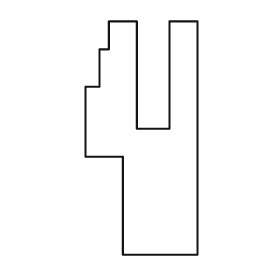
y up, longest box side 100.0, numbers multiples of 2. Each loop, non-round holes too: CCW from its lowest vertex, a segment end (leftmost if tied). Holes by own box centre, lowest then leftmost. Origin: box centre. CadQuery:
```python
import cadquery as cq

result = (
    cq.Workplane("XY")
    .moveTo(-8.0, -50.0)
    .lineTo(24.0, -50.0)
    .lineTo(24.0, 50.0)
    .lineTo(12.0, 50.0)
    .lineTo(12.0, 4.0)
    .lineTo(-2.0, 4.0)
    .lineTo(-2.0, 50.0)
    .lineTo(-14.0, 50.0)
    .lineTo(-14.0, 38.0)
    .lineTo(-18.0, 38.0)
    .lineTo(-18.0, 22.0)
    .lineTo(-24.0, 22.0)
    .lineTo(-24.0, -8.0)
    .lineTo(-8.0, -8.0)
    .close()
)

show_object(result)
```